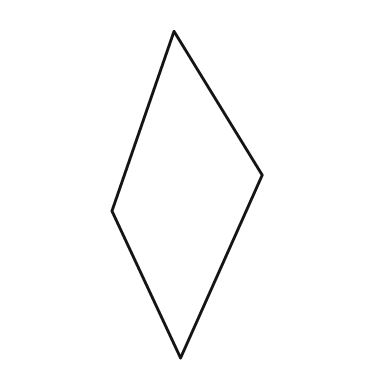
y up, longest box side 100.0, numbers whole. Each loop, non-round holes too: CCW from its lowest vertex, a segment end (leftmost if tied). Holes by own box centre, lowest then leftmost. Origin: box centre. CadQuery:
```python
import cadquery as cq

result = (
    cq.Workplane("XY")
    .moveTo(-2.0, -50.0)
    .lineTo(23.0, 6.0)
    .lineTo(-4.0, 50.0)
    .lineTo(-23.0, -5.0)
    .close()
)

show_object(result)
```